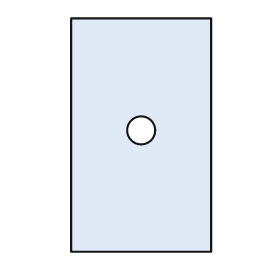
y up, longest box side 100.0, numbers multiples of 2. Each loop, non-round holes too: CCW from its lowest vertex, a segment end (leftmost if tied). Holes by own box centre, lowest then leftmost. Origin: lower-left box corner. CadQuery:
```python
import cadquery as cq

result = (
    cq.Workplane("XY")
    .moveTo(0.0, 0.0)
    .lineTo(60.0, 0.0)
    .lineTo(60.0, 100.0)
    .lineTo(0.0, 100.0)
    .close()
    .moveTo(30.0, 52.0)
    .circle(6.0)
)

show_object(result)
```